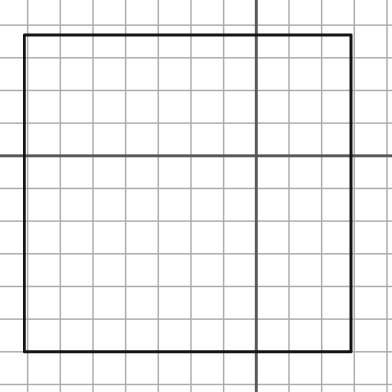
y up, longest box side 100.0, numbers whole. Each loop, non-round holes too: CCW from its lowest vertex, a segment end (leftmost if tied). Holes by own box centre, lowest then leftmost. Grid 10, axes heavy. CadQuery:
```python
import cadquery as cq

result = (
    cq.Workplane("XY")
    .moveTo(-71.0, -60.0)
    .lineTo(29.0, -60.0)
    .lineTo(29.0, 37.0)
    .lineTo(-71.0, 37.0)
    .close()
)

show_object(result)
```